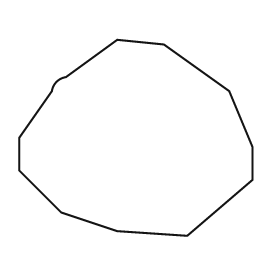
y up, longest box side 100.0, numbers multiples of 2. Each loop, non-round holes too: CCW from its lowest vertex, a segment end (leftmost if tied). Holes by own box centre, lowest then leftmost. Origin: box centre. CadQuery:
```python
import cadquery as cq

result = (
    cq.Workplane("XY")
    .moveTo(22.0, -42.0)
    .lineTo(50.0, -18.0)
    .lineTo(50.0, -4.0)
    .lineTo(40.0, 20.0)
    .lineTo(12.0, 40.0)
    .lineTo(-8.0, 42.0)
    .lineTo(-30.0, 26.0)
    .threePointArc((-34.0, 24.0), (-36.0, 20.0))
    .lineTo(-50.0, 0.0)
    .lineTo(-50.0, -14.0)
    .lineTo(-32.0, -32.0)
    .lineTo(-8.0, -40.0)
    .close()
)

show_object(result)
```